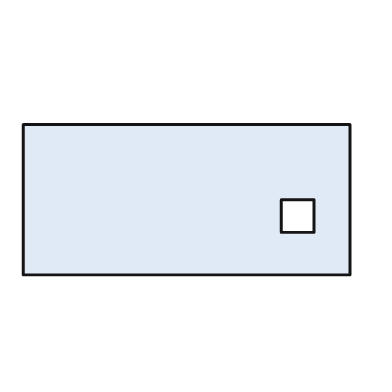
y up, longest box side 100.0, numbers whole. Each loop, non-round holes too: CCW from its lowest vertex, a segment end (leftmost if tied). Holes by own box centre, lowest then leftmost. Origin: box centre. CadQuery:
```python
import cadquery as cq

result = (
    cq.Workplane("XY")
    .moveTo(-50.0, -23.0)
    .lineTo(50.0, -23.0)
    .lineTo(50.0, 23.0)
    .lineTo(-50.0, 23.0)
    .close()
    .moveTo(29.0, -10.0)
    .lineTo(39.0, -10.0)
    .lineTo(39.0, 0.0)
    .lineTo(29.0, 0.0)
    .close()
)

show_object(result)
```